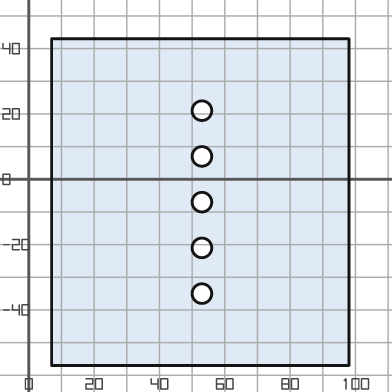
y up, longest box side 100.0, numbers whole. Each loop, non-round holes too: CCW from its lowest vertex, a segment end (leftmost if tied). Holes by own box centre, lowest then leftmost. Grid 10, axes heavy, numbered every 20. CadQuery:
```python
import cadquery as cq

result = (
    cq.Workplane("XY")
    .moveTo(7.0, -57.0)
    .lineTo(98.0, -57.0)
    .lineTo(98.0, 43.0)
    .lineTo(7.0, 43.0)
    .close()
    .moveTo(53.0, -35.0)
    .circle(3.0)
    .moveTo(53.0, -21.0)
    .circle(3.0)
    .moveTo(53.0, -7.0)
    .circle(3.0)
    .moveTo(53.0, 7.0)
    .circle(3.0)
    .moveTo(53.0, 21.0)
    .circle(3.0)
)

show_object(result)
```